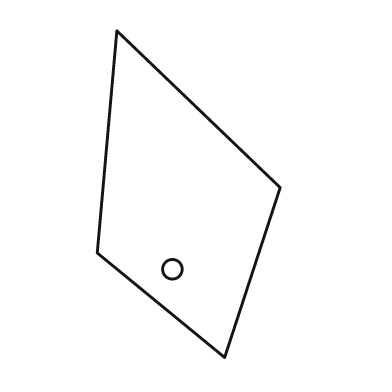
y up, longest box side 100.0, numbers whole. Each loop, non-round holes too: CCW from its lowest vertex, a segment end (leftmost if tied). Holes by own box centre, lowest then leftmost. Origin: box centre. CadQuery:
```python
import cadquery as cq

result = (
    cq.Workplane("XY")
    .moveTo(11.0, -50.0)
    .lineTo(28.0, 2.0)
    .lineTo(-22.0, 50.0)
    .lineTo(-28.0, -18.0)
    .close()
    .moveTo(-5.0, -23.0)
    .circle(3.0)
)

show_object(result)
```